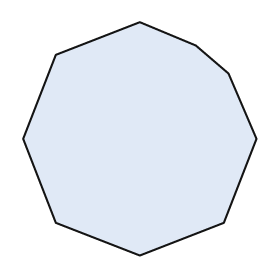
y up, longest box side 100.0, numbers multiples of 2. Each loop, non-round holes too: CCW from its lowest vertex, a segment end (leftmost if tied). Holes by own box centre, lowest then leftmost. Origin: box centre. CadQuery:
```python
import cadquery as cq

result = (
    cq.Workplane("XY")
    .moveTo(0.0, -50.0)
    .lineTo(36.0, -36.0)
    .lineTo(50.0, 0.0)
    .lineTo(38.0, 28.0)
    .lineTo(24.0, 40.0)
    .lineTo(0.0, 50.0)
    .lineTo(-36.0, 36.0)
    .lineTo(-50.0, 0.0)
    .lineTo(-36.0, -36.0)
    .close()
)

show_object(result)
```